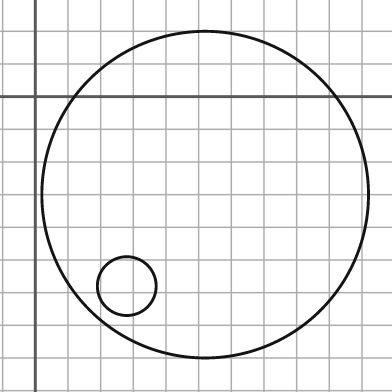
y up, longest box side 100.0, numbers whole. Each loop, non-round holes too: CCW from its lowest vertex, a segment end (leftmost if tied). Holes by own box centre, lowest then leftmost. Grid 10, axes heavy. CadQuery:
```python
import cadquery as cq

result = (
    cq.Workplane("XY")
    .moveTo(52.0, -30.0)
    .circle(50.0)
    .moveTo(28.0, -58.0)
    .circle(9.0)
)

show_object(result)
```